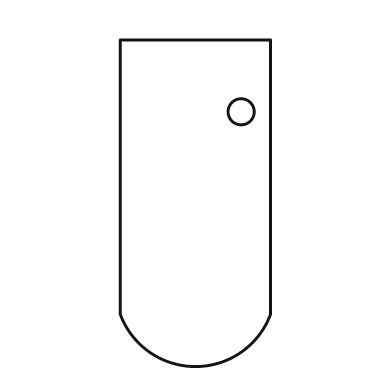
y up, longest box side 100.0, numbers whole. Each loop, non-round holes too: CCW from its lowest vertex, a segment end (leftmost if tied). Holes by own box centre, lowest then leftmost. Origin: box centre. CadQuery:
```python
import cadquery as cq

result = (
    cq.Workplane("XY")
    .moveTo(-23.0, -34.0)
    .threePointArc((0.0, -50.0), (23.0, -34.0))
    .lineTo(23.0, 50.0)
    .lineTo(-23.0, 50.0)
    .close()
    .moveTo(14.0, 28.0)
    .circle(4.0)
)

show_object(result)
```